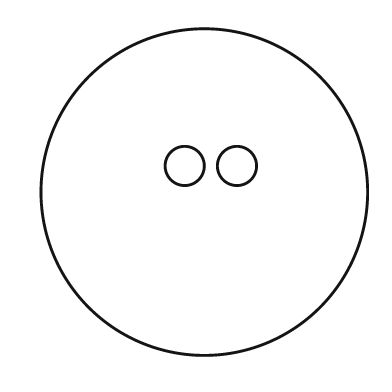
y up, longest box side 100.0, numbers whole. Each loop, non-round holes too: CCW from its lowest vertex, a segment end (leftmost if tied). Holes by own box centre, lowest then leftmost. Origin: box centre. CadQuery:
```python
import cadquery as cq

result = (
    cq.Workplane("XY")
    .moveTo(0.0, 0.0)
    .circle(50.0)
    .moveTo(-6.0, 8.0)
    .circle(6.0)
    .moveTo(10.0, 8.0)
    .circle(6.0)
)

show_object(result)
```